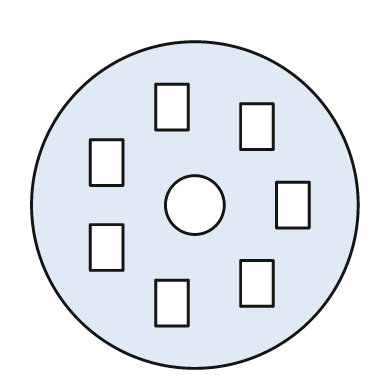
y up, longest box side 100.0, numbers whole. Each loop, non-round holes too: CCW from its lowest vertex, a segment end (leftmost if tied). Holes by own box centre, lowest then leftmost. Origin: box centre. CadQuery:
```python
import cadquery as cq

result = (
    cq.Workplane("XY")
    .moveTo(0.0, 0.0)
    .circle(50.0)
    .moveTo(-12.0, -37.0)
    .lineTo(-2.0, -37.0)
    .lineTo(-2.0, -23.0)
    .lineTo(-12.0, -23.0)
    .close()
    .moveTo(14.0, -31.0)
    .lineTo(24.0, -31.0)
    .lineTo(24.0, -17.0)
    .lineTo(14.0, -17.0)
    .close()
    .moveTo(-32.0, -20.0)
    .lineTo(-22.0, -20.0)
    .lineTo(-22.0, -6.0)
    .lineTo(-32.0, -6.0)
    .close()
    .moveTo(0.0, 0.0)
    .circle(9.0)
    .moveTo(25.0, -7.0)
    .lineTo(35.0, -7.0)
    .lineTo(35.0, 7.0)
    .lineTo(25.0, 7.0)
    .close()
    .moveTo(-32.0, 6.0)
    .lineTo(-22.0, 6.0)
    .lineTo(-22.0, 20.0)
    .lineTo(-32.0, 20.0)
    .close()
    .moveTo(14.0, 17.0)
    .lineTo(24.0, 17.0)
    .lineTo(24.0, 31.0)
    .lineTo(14.0, 31.0)
    .close()
    .moveTo(-12.0, 23.0)
    .lineTo(-2.0, 23.0)
    .lineTo(-2.0, 37.0)
    .lineTo(-12.0, 37.0)
    .close()
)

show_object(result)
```